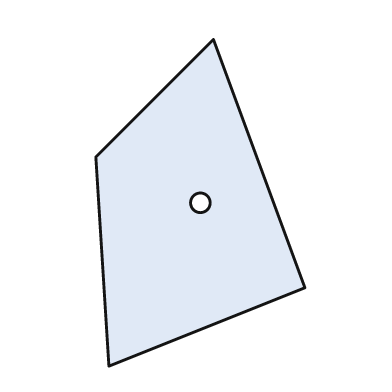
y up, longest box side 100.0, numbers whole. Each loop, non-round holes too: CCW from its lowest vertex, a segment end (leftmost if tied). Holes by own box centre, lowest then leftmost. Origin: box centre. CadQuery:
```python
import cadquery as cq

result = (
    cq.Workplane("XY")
    .moveTo(-28.0, -50.0)
    .lineTo(32.0, -26.0)
    .lineTo(4.0, 50.0)
    .lineTo(-32.0, 14.0)
    .close()
    .moveTo(0.0, 0.0)
    .circle(3.0)
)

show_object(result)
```